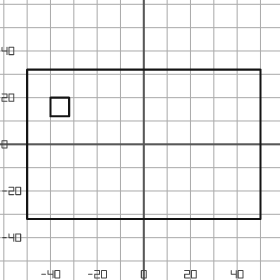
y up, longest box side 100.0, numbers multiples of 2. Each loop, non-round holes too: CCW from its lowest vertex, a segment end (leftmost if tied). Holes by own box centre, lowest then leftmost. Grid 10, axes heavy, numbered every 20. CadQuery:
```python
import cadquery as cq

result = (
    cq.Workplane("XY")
    .moveTo(-50.0, -32.0)
    .lineTo(50.0, -32.0)
    .lineTo(50.0, 32.0)
    .lineTo(-50.0, 32.0)
    .close()
    .moveTo(-40.0, 12.0)
    .lineTo(-32.0, 12.0)
    .lineTo(-32.0, 20.0)
    .lineTo(-40.0, 20.0)
    .close()
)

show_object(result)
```